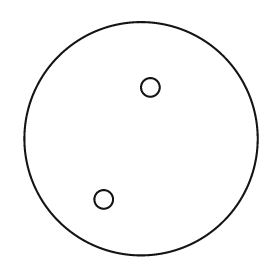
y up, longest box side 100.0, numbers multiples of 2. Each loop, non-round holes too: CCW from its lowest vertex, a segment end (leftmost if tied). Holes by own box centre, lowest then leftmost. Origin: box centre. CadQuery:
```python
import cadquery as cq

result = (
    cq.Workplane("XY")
    .moveTo(0.0, 0.0)
    .circle(50.0)
    .moveTo(-16.0, -26.0)
    .circle(4.0)
    .moveTo(4.0, 22.0)
    .circle(4.0)
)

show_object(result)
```